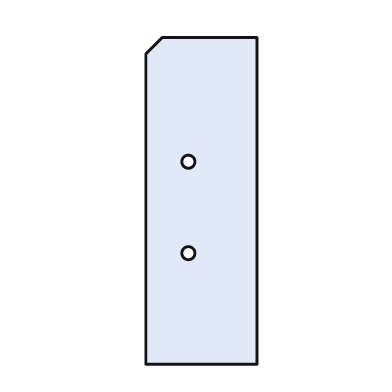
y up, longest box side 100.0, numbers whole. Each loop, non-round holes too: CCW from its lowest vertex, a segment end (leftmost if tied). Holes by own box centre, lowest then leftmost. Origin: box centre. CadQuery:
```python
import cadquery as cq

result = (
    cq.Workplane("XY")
    .moveTo(-17.0, -50.0)
    .lineTo(17.0, -50.0)
    .lineTo(17.0, 50.0)
    .lineTo(-12.0, 50.0)
    .lineTo(-17.0, 45.0)
    .close()
    .moveTo(-4.0, -16.0)
    .circle(2.0)
    .moveTo(-4.0, 12.0)
    .circle(2.0)
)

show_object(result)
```